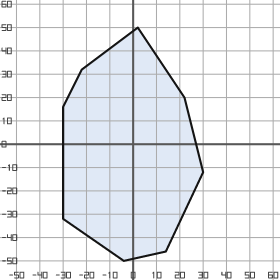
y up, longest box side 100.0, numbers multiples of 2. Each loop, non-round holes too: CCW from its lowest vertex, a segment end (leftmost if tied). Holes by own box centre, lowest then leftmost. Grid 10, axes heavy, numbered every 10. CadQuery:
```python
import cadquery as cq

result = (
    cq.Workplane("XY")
    .moveTo(-4.0, -50.0)
    .lineTo(14.0, -46.0)
    .lineTo(30.0, -12.0)
    .lineTo(22.0, 20.0)
    .lineTo(2.0, 50.0)
    .lineTo(-22.0, 32.0)
    .lineTo(-30.0, 16.0)
    .lineTo(-30.0, -32.0)
    .close()
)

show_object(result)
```